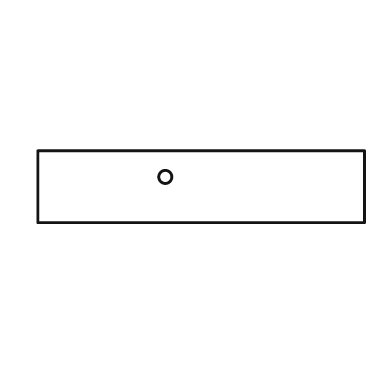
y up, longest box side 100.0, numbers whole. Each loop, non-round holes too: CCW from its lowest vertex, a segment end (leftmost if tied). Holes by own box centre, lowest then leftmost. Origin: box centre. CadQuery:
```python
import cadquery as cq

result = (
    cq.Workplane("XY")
    .moveTo(-50.0, -11.0)
    .lineTo(50.0, -11.0)
    .lineTo(50.0, 11.0)
    .lineTo(-50.0, 11.0)
    .close()
    .moveTo(-11.0, 3.0)
    .circle(2.0)
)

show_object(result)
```